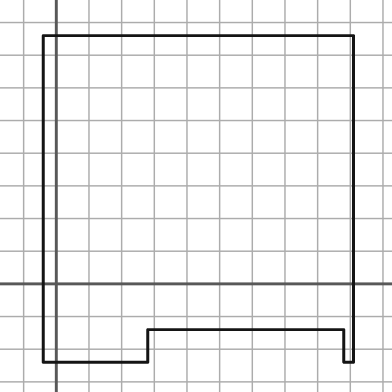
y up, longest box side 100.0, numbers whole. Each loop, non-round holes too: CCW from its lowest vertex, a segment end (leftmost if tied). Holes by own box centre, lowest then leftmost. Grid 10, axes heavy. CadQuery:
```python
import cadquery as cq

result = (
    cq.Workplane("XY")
    .moveTo(-4.0, -24.0)
    .lineTo(28.0, -24.0)
    .lineTo(28.0, -14.0)
    .lineTo(88.0, -14.0)
    .lineTo(88.0, -24.0)
    .lineTo(91.0, -24.0)
    .lineTo(91.0, 76.0)
    .lineTo(-4.0, 76.0)
    .close()
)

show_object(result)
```